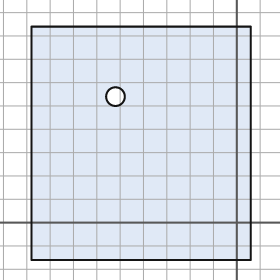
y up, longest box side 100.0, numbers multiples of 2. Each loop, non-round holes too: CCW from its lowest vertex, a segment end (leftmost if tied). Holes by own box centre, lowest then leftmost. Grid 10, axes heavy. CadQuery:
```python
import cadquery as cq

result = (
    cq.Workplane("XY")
    .moveTo(-88.0, -16.0)
    .lineTo(6.0, -16.0)
    .lineTo(6.0, 84.0)
    .lineTo(-88.0, 84.0)
    .close()
    .moveTo(-52.0, 54.0)
    .circle(4.0)
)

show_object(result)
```